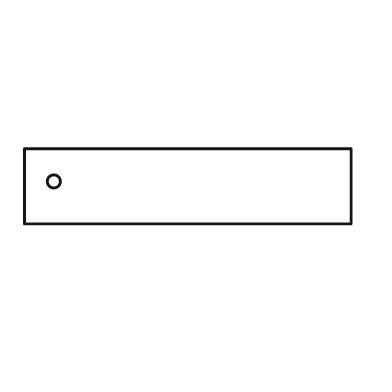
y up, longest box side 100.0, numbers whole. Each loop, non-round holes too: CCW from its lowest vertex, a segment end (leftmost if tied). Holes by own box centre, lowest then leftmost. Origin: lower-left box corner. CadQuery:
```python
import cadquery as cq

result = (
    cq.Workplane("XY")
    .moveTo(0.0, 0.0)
    .lineTo(100.0, 0.0)
    .lineTo(100.0, 23.0)
    .lineTo(0.0, 23.0)
    .close()
    .moveTo(9.0, 13.0)
    .circle(2.0)
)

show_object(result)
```